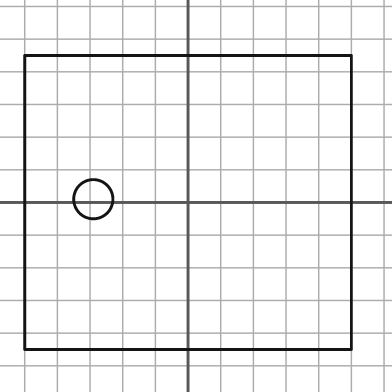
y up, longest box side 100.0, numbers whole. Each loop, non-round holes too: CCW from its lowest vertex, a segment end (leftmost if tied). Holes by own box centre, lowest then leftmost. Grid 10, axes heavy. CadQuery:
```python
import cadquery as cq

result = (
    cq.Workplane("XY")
    .moveTo(-50.0, -45.0)
    .lineTo(50.0, -45.0)
    .lineTo(50.0, 45.0)
    .lineTo(-50.0, 45.0)
    .close()
    .moveTo(-29.0, 1.0)
    .circle(6.0)
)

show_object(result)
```